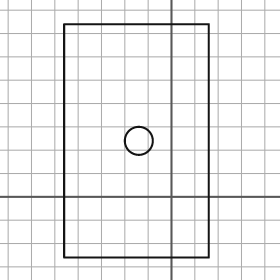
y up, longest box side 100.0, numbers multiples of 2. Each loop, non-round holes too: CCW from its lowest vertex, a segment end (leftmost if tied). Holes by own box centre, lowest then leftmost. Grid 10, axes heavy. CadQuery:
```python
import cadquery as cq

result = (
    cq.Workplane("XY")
    .moveTo(-46.0, -26.0)
    .lineTo(16.0, -26.0)
    .lineTo(16.0, 74.0)
    .lineTo(-46.0, 74.0)
    .close()
    .moveTo(-14.0, 24.0)
    .circle(6.0)
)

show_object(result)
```